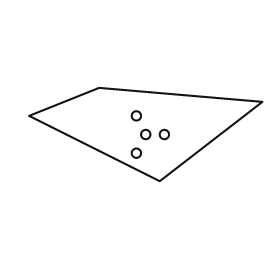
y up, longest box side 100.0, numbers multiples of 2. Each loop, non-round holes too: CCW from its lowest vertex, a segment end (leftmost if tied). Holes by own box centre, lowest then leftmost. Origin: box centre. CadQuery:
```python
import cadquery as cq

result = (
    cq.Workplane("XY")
    .moveTo(6.0, -20.0)
    .lineTo(50.0, 14.0)
    .lineTo(-20.0, 20.0)
    .lineTo(-50.0, 8.0)
    .close()
    .moveTo(-4.0, -8.0)
    .circle(2.0)
    .moveTo(0.0, 0.0)
    .circle(2.0)
    .moveTo(8.0, 0.0)
    .circle(2.0)
    .moveTo(-4.0, 8.0)
    .circle(2.0)
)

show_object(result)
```